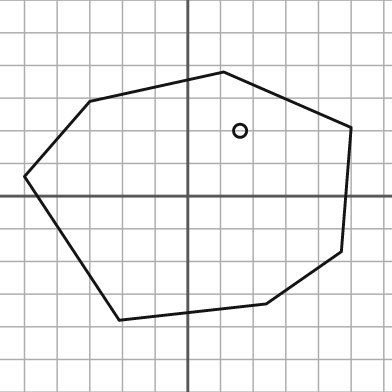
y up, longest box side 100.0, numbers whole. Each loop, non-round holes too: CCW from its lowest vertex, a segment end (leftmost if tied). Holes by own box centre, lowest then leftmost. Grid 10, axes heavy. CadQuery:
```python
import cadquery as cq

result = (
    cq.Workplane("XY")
    .moveTo(-21.0, -38.0)
    .lineTo(24.0, -33.0)
    .lineTo(47.0, -17.0)
    .lineTo(50.0, 21.0)
    .lineTo(11.0, 38.0)
    .lineTo(-30.0, 29.0)
    .lineTo(-50.0, 6.0)
    .close()
    .moveTo(16.0, 20.0)
    .circle(2.0)
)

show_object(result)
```